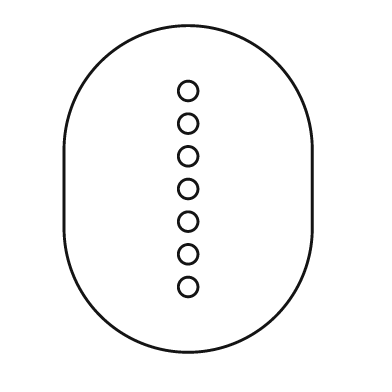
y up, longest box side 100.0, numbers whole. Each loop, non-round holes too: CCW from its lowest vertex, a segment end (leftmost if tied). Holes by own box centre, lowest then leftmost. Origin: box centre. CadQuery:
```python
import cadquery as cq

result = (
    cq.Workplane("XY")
    .moveTo(-38.0, -12.0)
    .threePointArc((0.0, -50.0), (38.0, -12.0))
    .lineTo(38.0, 12.0)
    .threePointArc((0.0, 50.0), (-38.0, 12.0))
    .close()
    .moveTo(0.0, -30.0)
    .circle(3.0)
    .moveTo(0.0, -20.0)
    .circle(3.0)
    .moveTo(0.0, -10.0)
    .circle(3.0)
    .moveTo(0.0, 0.0)
    .circle(3.0)
    .moveTo(0.0, 10.0)
    .circle(3.0)
    .moveTo(0.0, 20.0)
    .circle(3.0)
    .moveTo(0.0, 30.0)
    .circle(3.0)
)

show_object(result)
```